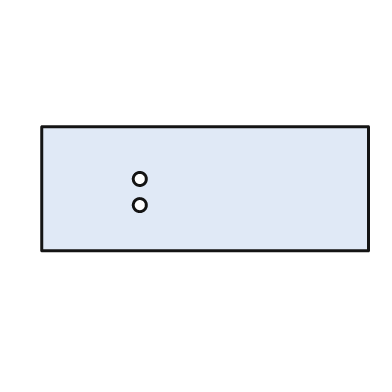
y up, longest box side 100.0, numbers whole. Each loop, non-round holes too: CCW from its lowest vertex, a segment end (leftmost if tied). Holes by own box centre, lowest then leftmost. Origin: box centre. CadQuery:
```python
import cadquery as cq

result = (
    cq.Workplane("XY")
    .moveTo(-50.0, -19.0)
    .lineTo(50.0, -19.0)
    .lineTo(50.0, 19.0)
    .lineTo(-50.0, 19.0)
    .close()
    .moveTo(-20.0, -5.0)
    .circle(2.0)
    .moveTo(-20.0, 3.0)
    .circle(2.0)
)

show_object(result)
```